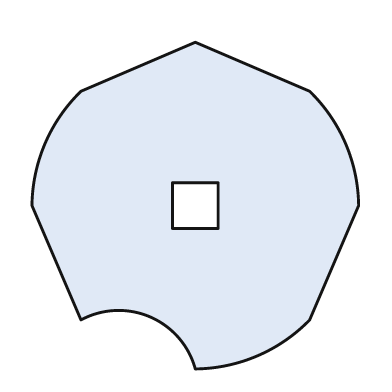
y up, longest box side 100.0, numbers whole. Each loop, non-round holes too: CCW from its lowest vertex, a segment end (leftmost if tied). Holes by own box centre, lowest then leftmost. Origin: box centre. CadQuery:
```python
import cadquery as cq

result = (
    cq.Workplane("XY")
    .moveTo(0.0, -50.0)
    .threePointArc((19.0, -46.0), (35.0, -35.0))
    .lineTo(50.0, 0.0)
    .threePointArc((46.0, 19.0), (35.0, 35.0))
    .lineTo(0.0, 50.0)
    .lineTo(-35.0, 35.0)
    .threePointArc((-46.0, 19.0), (-50.0, 0.0))
    .lineTo(-35.0, -35.0)
    .threePointArc((-14.0, -34.0), (0.0, -50.0))
    .close()
    .moveTo(-7.0, -7.0)
    .lineTo(7.0, -7.0)
    .lineTo(7.0, 7.0)
    .lineTo(-7.0, 7.0)
    .close()
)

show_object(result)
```